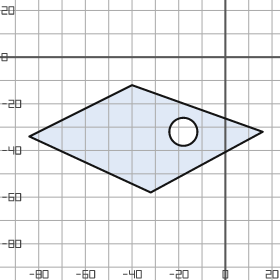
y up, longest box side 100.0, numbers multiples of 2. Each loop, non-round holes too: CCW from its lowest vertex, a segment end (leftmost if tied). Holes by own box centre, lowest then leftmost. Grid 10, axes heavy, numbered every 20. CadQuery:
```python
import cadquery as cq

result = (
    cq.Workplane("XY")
    .moveTo(-32.0, -58.0)
    .lineTo(16.0, -32.0)
    .lineTo(-40.0, -12.0)
    .lineTo(-84.0, -34.0)
    .close()
    .moveTo(-18.0, -32.0)
    .circle(6.0)
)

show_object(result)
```